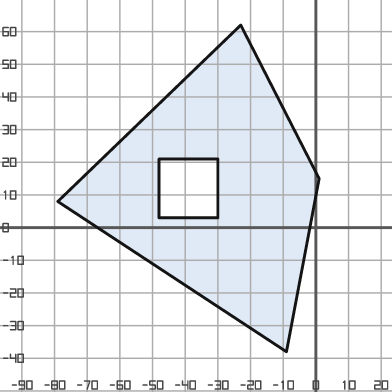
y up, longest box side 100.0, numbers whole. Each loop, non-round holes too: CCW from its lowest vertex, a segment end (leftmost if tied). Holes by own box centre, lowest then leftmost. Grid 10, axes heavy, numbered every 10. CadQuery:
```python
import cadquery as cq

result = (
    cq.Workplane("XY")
    .moveTo(-9.0, -38.0)
    .lineTo(1.0, 15.0)
    .lineTo(-23.0, 62.0)
    .lineTo(-79.0, 8.0)
    .close()
    .moveTo(-48.0, 3.0)
    .lineTo(-30.0, 3.0)
    .lineTo(-30.0, 21.0)
    .lineTo(-48.0, 21.0)
    .close()
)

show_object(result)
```